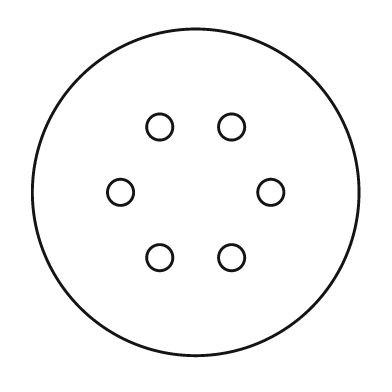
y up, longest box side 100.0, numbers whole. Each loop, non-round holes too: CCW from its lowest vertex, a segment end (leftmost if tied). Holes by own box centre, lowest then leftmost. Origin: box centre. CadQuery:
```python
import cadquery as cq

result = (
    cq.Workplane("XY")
    .moveTo(0.0, 0.0)
    .circle(50.0)
    .moveTo(-11.0, -20.0)
    .circle(4.0)
    .moveTo(11.0, -20.0)
    .circle(4.0)
    .moveTo(-23.0, 0.0)
    .circle(4.0)
    .moveTo(23.0, 0.0)
    .circle(4.0)
    .moveTo(-11.0, 20.0)
    .circle(4.0)
    .moveTo(11.0, 20.0)
    .circle(4.0)
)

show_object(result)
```